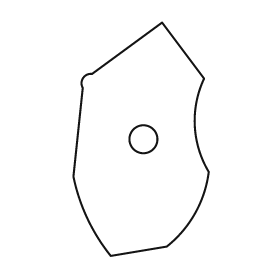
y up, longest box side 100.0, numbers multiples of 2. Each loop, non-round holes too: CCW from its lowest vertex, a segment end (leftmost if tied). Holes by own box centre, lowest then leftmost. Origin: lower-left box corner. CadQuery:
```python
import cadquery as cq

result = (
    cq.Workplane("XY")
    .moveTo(16.0, 0.0)
    .lineTo(40.0, 4.0)
    .threePointArc((52.0, 18.0), (58.0, 36.0))
    .threePointArc((52.0, 56.0), (56.0, 76.0))
    .lineTo(38.0, 100.0)
    .lineTo(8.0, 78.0)
    .threePointArc((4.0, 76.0), (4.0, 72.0))
    .lineTo(0.0, 34.0)
    .threePointArc((6.0, 16.0), (16.0, 0.0))
    .close()
    .moveTo(30.0, 50.0)
    .circle(6.0)
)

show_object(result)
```